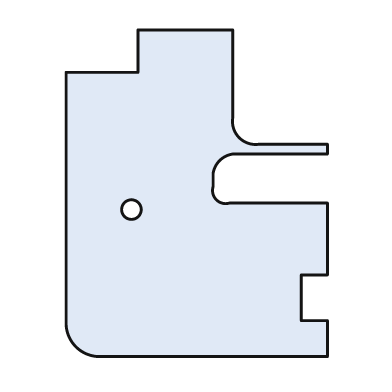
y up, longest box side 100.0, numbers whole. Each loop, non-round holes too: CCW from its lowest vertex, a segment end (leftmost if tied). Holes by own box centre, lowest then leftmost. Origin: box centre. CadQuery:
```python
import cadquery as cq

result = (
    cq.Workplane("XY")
    .moveTo(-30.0, -50.0)
    .lineTo(40.0, -50.0)
    .lineTo(40.0, -39.0)
    .lineTo(32.0, -39.0)
    .lineTo(32.0, -25.0)
    .lineTo(40.0, -25.0)
    .lineTo(40.0, -3.0)
    .lineTo(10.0, -3.0)
    .threePointArc((6.0, -2.0), (5.0, 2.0))
    .lineTo(5.0, 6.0)
    .threePointArc((7.0, 10.0), (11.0, 12.0))
    .lineTo(40.0, 12.0)
    .lineTo(40.0, 15.0)
    .lineTo(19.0, 15.0)
    .threePointArc((13.0, 17.0), (11.0, 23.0))
    .lineTo(11.0, 50.0)
    .lineTo(-18.0, 50.0)
    .lineTo(-18.0, 37.0)
    .lineTo(-40.0, 37.0)
    .lineTo(-40.0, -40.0)
    .threePointArc((-37.0, -47.0), (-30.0, -50.0))
    .close()
    .moveTo(-20.0, -5.0)
    .circle(3.0)
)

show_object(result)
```